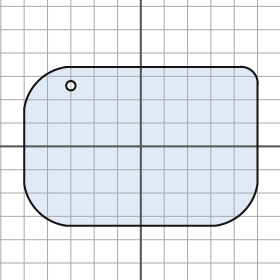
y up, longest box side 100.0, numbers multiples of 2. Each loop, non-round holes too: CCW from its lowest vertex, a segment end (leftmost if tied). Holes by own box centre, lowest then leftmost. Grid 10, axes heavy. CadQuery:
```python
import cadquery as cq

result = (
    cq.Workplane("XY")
    .moveTo(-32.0, -34.0)
    .lineTo(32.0, -34.0)
    .threePointArc((44.0, -28.0), (50.0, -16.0))
    .lineTo(50.0, 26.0)
    .threePointArc((48.0, 32.0), (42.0, 34.0))
    .lineTo(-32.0, 34.0)
    .threePointArc((-44.0, 28.0), (-50.0, 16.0))
    .lineTo(-50.0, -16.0)
    .threePointArc((-44.0, -28.0), (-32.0, -34.0))
    .close()
    .moveTo(-30.0, 26.0)
    .circle(2.0)
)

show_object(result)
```